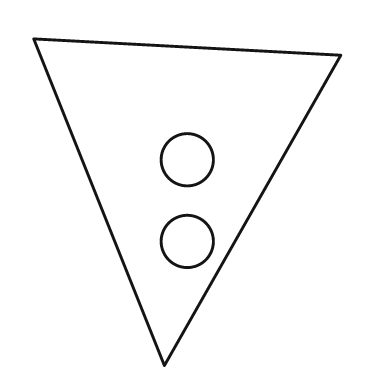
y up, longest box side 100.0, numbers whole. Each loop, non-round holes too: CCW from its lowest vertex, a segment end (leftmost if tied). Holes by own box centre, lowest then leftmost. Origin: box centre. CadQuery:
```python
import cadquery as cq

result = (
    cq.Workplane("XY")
    .moveTo(-7.0, -50.0)
    .lineTo(47.0, 45.0)
    .lineTo(-47.0, 50.0)
    .close()
    .moveTo(0.0, -12.0)
    .circle(8.0)
    .moveTo(0.0, 13.0)
    .circle(8.0)
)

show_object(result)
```